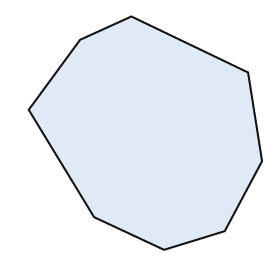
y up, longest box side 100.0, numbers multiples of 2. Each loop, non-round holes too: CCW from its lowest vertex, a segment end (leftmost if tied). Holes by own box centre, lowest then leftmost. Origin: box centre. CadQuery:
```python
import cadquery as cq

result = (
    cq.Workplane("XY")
    .moveTo(8.0, -50.0)
    .lineTo(34.0, -42.0)
    .lineTo(50.0, -12.0)
    .lineTo(44.0, 26.0)
    .lineTo(-6.0, 50.0)
    .lineTo(-28.0, 40.0)
    .lineTo(-50.0, 10.0)
    .lineTo(-22.0, -36.0)
    .close()
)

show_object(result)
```